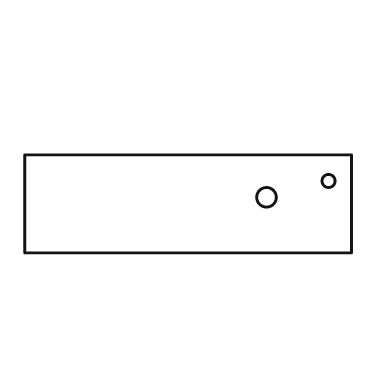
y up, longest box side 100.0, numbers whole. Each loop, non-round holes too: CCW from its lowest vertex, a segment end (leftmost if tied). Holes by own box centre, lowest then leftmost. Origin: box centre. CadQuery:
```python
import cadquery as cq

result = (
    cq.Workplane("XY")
    .moveTo(-50.0, -15.0)
    .lineTo(50.0, -15.0)
    .lineTo(50.0, 15.0)
    .lineTo(-50.0, 15.0)
    .close()
    .moveTo(24.0, 2.0)
    .circle(3.0)
    .moveTo(43.0, 7.0)
    .circle(2.0)
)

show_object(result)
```